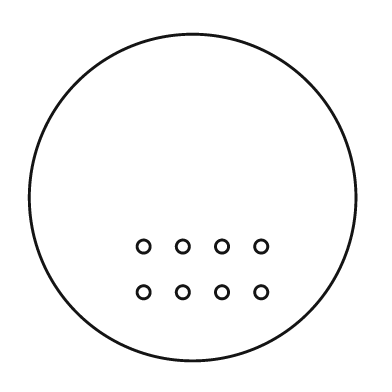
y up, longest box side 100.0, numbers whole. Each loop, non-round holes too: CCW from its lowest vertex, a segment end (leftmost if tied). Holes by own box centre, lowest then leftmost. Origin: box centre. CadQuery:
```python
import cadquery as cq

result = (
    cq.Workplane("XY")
    .moveTo(0.0, 0.0)
    .circle(50.0)
    .moveTo(-15.0, -29.0)
    .circle(2.0)
    .moveTo(-3.0, -29.0)
    .circle(2.0)
    .moveTo(9.0, -29.0)
    .circle(2.0)
    .moveTo(21.0, -29.0)
    .circle(2.0)
    .moveTo(-15.0, -15.0)
    .circle(2.0)
    .moveTo(-3.0, -15.0)
    .circle(2.0)
    .moveTo(9.0, -15.0)
    .circle(2.0)
    .moveTo(21.0, -15.0)
    .circle(2.0)
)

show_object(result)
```